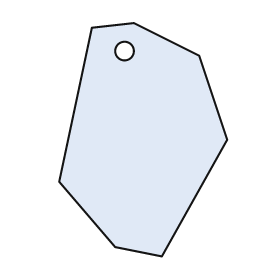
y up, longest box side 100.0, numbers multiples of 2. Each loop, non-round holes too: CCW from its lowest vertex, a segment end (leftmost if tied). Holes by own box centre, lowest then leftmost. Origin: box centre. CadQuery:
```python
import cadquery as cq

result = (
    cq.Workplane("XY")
    .moveTo(8.0, -50.0)
    .lineTo(36.0, 0.0)
    .lineTo(24.0, 36.0)
    .lineTo(-4.0, 50.0)
    .lineTo(-22.0, 48.0)
    .lineTo(-36.0, -18.0)
    .lineTo(-12.0, -46.0)
    .close()
    .moveTo(-8.0, 38.0)
    .circle(4.0)
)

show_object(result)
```